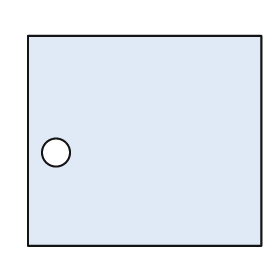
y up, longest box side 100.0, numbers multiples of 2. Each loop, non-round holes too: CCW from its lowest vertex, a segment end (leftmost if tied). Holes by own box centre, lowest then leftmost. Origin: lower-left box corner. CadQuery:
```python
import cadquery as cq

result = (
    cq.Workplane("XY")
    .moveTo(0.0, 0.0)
    .lineTo(100.0, 0.0)
    .lineTo(100.0, 90.0)
    .lineTo(0.0, 90.0)
    .close()
    .moveTo(12.0, 40.0)
    .circle(6.0)
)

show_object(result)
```